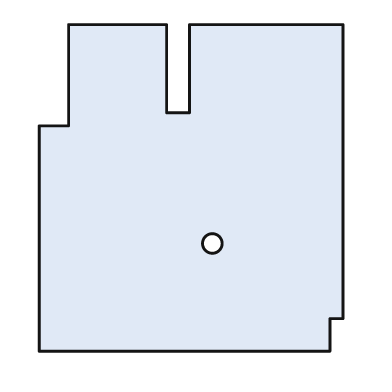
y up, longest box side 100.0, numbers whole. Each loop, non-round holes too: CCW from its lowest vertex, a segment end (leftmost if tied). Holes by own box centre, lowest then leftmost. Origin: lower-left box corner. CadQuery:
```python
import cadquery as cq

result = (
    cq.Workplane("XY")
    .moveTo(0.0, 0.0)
    .lineTo(89.0, 0.0)
    .lineTo(89.0, 10.0)
    .lineTo(93.0, 10.0)
    .lineTo(93.0, 100.0)
    .lineTo(46.0, 100.0)
    .lineTo(46.0, 73.0)
    .lineTo(39.0, 73.0)
    .lineTo(39.0, 100.0)
    .lineTo(9.0, 100.0)
    .lineTo(9.0, 69.0)
    .lineTo(0.0, 69.0)
    .close()
    .moveTo(53.0, 33.0)
    .circle(3.0)
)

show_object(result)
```